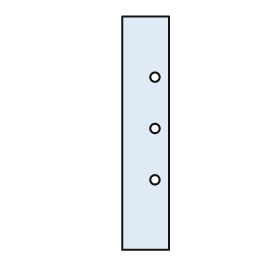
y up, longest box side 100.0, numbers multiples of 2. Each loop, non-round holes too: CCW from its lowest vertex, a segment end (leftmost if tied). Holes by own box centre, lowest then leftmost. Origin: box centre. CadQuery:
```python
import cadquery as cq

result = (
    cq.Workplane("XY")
    .moveTo(-10.0, -50.0)
    .lineTo(10.0, -50.0)
    .lineTo(10.0, 50.0)
    .lineTo(-10.0, 50.0)
    .close()
    .moveTo(4.0, -20.0)
    .circle(2.0)
    .moveTo(4.0, 2.0)
    .circle(2.0)
    .moveTo(4.0, 24.0)
    .circle(2.0)
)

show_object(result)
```